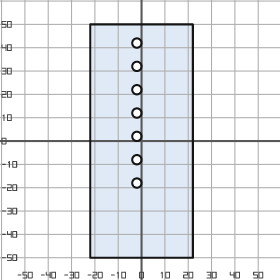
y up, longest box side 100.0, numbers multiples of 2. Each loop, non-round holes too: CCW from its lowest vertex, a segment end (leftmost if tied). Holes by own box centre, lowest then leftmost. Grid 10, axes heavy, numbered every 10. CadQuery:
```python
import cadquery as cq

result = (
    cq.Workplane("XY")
    .moveTo(-22.0, -50.0)
    .lineTo(22.0, -50.0)
    .lineTo(22.0, 50.0)
    .lineTo(-22.0, 50.0)
    .close()
    .moveTo(-2.0, -18.0)
    .circle(2.0)
    .moveTo(-2.0, -8.0)
    .circle(2.0)
    .moveTo(-2.0, 2.0)
    .circle(2.0)
    .moveTo(-2.0, 12.0)
    .circle(2.0)
    .moveTo(-2.0, 22.0)
    .circle(2.0)
    .moveTo(-2.0, 32.0)
    .circle(2.0)
    .moveTo(-2.0, 42.0)
    .circle(2.0)
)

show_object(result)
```